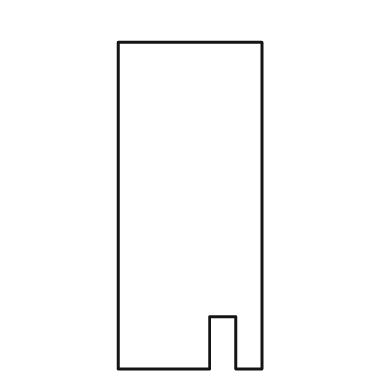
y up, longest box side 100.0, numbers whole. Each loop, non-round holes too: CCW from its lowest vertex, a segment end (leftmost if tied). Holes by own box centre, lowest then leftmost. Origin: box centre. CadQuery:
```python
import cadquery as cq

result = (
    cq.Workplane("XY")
    .moveTo(-22.0, -50.0)
    .lineTo(6.0, -50.0)
    .lineTo(6.0, -34.0)
    .lineTo(14.0, -34.0)
    .lineTo(14.0, -50.0)
    .lineTo(22.0, -50.0)
    .lineTo(22.0, 50.0)
    .lineTo(-22.0, 50.0)
    .close()
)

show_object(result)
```